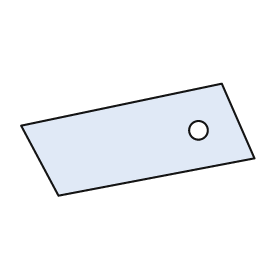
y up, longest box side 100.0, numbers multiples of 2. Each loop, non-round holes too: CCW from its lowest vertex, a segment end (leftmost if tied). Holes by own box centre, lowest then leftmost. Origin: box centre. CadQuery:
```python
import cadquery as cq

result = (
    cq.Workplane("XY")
    .moveTo(-34.0, -24.0)
    .lineTo(50.0, -8.0)
    .lineTo(36.0, 24.0)
    .lineTo(-50.0, 6.0)
    .close()
    .moveTo(26.0, 4.0)
    .circle(4.0)
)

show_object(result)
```